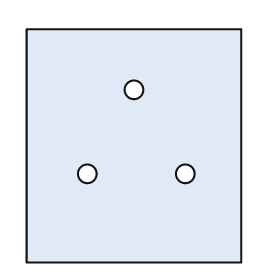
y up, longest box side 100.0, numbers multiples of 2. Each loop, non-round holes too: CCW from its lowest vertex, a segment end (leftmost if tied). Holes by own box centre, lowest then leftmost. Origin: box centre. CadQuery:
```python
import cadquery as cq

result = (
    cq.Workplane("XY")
    .moveTo(-46.0, -50.0)
    .lineTo(46.0, -50.0)
    .lineTo(46.0, 50.0)
    .lineTo(-46.0, 50.0)
    .close()
    .moveTo(-20.0, -12.0)
    .circle(4.0)
    .moveTo(22.0, -12.0)
    .circle(4.0)
    .moveTo(0.0, 24.0)
    .circle(4.0)
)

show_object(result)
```